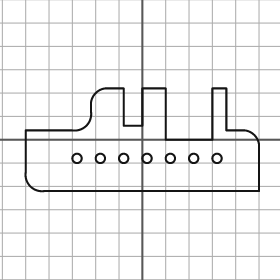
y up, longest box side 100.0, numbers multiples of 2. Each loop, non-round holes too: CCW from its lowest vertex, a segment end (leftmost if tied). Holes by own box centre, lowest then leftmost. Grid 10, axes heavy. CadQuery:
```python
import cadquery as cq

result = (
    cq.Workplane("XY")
    .moveTo(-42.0, -22.0)
    .lineTo(50.0, -22.0)
    .lineTo(50.0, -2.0)
    .threePointArc((48.0, 2.0), (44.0, 4.0))
    .lineTo(36.0, 4.0)
    .lineTo(36.0, 22.0)
    .lineTo(30.0, 22.0)
    .lineTo(30.0, 0.0)
    .lineTo(10.0, 0.0)
    .lineTo(10.0, 22.0)
    .lineTo(0.0, 22.0)
    .lineTo(0.0, 6.0)
    .lineTo(-8.0, 6.0)
    .lineTo(-8.0, 22.0)
    .lineTo(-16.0, 22.0)
    .threePointArc((-20.0, 20.0), (-22.0, 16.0))
    .lineTo(-22.0, 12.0)
    .threePointArc((-24.0, 6.0), (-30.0, 4.0))
    .lineTo(-50.0, 4.0)
    .lineTo(-50.0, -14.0)
    .threePointArc((-48.0, -20.0), (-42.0, -22.0))
    .close()
    .moveTo(-28.0, -8.0)
    .circle(2.0)
    .moveTo(-18.0, -8.0)
    .circle(2.0)
    .moveTo(-8.0, -8.0)
    .circle(2.0)
    .moveTo(2.0, -8.0)
    .circle(2.0)
    .moveTo(12.0, -8.0)
    .circle(2.0)
    .moveTo(22.0, -8.0)
    .circle(2.0)
    .moveTo(32.0, -8.0)
    .circle(2.0)
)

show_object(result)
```